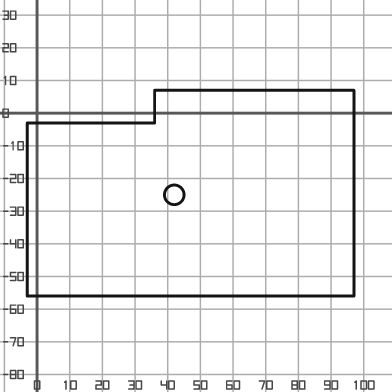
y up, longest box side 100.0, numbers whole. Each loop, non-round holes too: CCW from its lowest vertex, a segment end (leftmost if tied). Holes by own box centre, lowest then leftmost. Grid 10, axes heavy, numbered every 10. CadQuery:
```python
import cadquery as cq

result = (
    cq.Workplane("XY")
    .moveTo(-3.0, -56.0)
    .lineTo(97.0, -56.0)
    .lineTo(97.0, 7.0)
    .lineTo(36.0, 7.0)
    .lineTo(36.0, -3.0)
    .lineTo(-3.0, -3.0)
    .close()
    .moveTo(42.0, -25.0)
    .circle(3.0)
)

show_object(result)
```